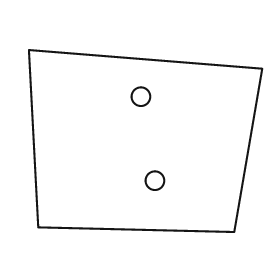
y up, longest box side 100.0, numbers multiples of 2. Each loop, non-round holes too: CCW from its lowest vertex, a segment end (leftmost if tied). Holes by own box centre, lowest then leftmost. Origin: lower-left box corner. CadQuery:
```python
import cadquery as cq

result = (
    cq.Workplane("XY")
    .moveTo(88.0, 0.0)
    .lineTo(100.0, 70.0)
    .lineTo(0.0, 78.0)
    .lineTo(4.0, 2.0)
    .close()
    .moveTo(54.0, 22.0)
    .circle(4.0)
    .moveTo(48.0, 58.0)
    .circle(4.0)
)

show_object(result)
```